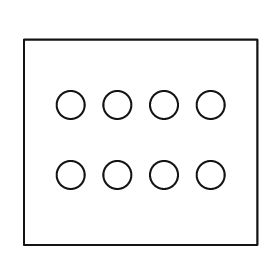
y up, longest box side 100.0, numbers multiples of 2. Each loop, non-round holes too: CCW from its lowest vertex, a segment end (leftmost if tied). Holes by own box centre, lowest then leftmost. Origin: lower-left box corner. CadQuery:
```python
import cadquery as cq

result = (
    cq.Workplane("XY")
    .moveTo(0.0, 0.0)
    .lineTo(100.0, 0.0)
    .lineTo(100.0, 88.0)
    .lineTo(0.0, 88.0)
    .close()
    .moveTo(20.0, 30.0)
    .circle(6.0)
    .moveTo(40.0, 30.0)
    .circle(6.0)
    .moveTo(60.0, 30.0)
    .circle(6.0)
    .moveTo(80.0, 30.0)
    .circle(6.0)
    .moveTo(20.0, 60.0)
    .circle(6.0)
    .moveTo(40.0, 60.0)
    .circle(6.0)
    .moveTo(60.0, 60.0)
    .circle(6.0)
    .moveTo(80.0, 60.0)
    .circle(6.0)
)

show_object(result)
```